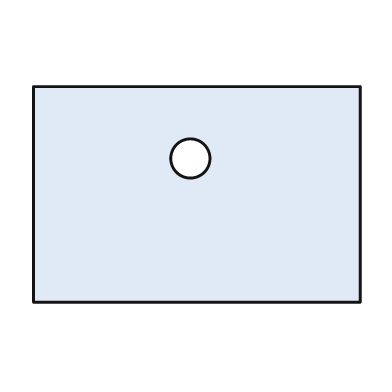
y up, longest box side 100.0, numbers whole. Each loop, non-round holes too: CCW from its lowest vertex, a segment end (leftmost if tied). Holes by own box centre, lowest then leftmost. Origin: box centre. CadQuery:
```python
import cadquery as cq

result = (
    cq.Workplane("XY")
    .moveTo(-50.0, -33.0)
    .lineTo(50.0, -33.0)
    .lineTo(50.0, 33.0)
    .lineTo(-50.0, 33.0)
    .close()
    .moveTo(-2.0, 11.0)
    .circle(6.0)
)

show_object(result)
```